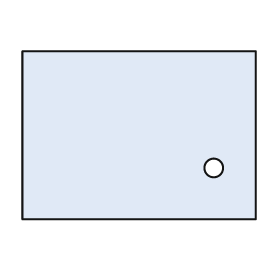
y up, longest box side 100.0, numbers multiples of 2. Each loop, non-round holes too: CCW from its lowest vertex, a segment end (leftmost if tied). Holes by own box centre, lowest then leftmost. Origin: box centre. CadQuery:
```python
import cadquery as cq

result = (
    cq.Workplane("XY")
    .moveTo(-50.0, -36.0)
    .lineTo(50.0, -36.0)
    .lineTo(50.0, 36.0)
    .lineTo(-50.0, 36.0)
    .close()
    .moveTo(32.0, -14.0)
    .circle(4.0)
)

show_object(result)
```